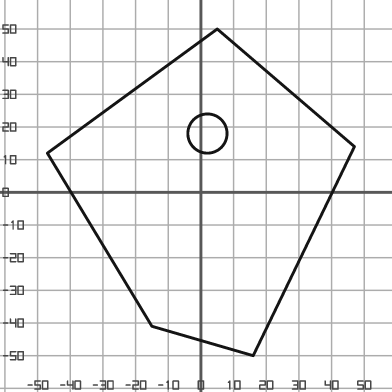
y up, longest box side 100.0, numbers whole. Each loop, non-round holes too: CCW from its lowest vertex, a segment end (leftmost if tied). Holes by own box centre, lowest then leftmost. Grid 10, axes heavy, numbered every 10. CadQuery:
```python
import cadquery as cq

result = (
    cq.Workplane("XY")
    .moveTo(16.0, -50.0)
    .lineTo(47.0, 14.0)
    .lineTo(5.0, 50.0)
    .lineTo(-47.0, 12.0)
    .lineTo(-15.0, -41.0)
    .close()
    .moveTo(2.0, 18.0)
    .circle(6.0)
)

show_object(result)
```